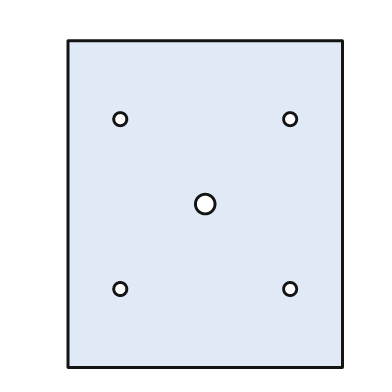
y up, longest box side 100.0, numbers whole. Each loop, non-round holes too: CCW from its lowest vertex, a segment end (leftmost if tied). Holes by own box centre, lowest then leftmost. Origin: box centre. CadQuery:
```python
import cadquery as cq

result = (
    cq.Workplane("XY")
    .moveTo(-42.0, -50.0)
    .lineTo(42.0, -50.0)
    .lineTo(42.0, 50.0)
    .lineTo(-42.0, 50.0)
    .close()
    .moveTo(-26.0, -26.0)
    .circle(2.0)
    .moveTo(26.0, -26.0)
    .circle(2.0)
    .moveTo(0.0, 0.0)
    .circle(3.0)
    .moveTo(-26.0, 26.0)
    .circle(2.0)
    .moveTo(26.0, 26.0)
    .circle(2.0)
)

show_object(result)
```